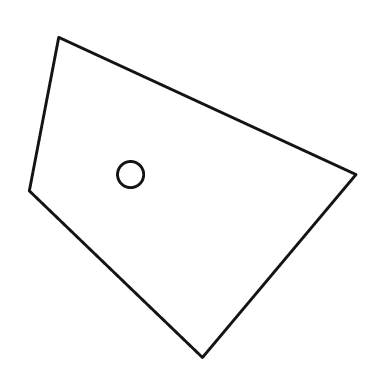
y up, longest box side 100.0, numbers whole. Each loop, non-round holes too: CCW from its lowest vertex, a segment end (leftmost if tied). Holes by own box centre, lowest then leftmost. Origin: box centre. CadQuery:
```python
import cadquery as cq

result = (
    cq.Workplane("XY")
    .moveTo(3.0, -49.0)
    .lineTo(50.0, 7.0)
    .lineTo(-41.0, 49.0)
    .lineTo(-50.0, 2.0)
    .close()
    .moveTo(-19.0, 7.0)
    .circle(4.0)
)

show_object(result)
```